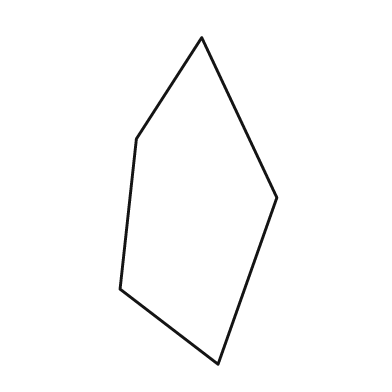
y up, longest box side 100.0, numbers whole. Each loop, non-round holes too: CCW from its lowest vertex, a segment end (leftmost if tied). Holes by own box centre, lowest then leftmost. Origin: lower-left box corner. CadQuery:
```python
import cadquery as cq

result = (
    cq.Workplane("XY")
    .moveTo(30.0, 0.0)
    .lineTo(48.0, 51.0)
    .lineTo(25.0, 100.0)
    .lineTo(5.0, 69.0)
    .lineTo(0.0, 23.0)
    .close()
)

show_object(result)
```